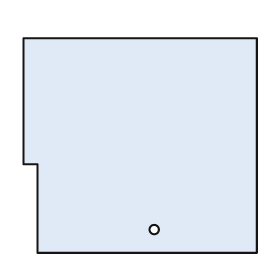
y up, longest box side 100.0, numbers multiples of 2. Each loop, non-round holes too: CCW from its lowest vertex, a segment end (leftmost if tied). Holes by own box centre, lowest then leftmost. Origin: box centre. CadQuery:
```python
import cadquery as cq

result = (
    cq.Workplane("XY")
    .moveTo(-44.0, -46.0)
    .lineTo(50.0, -46.0)
    .lineTo(50.0, 46.0)
    .lineTo(-50.0, 46.0)
    .lineTo(-50.0, -8.0)
    .lineTo(-44.0, -8.0)
    .close()
    .moveTo(6.0, -36.0)
    .circle(2.0)
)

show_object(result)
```